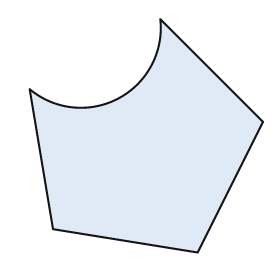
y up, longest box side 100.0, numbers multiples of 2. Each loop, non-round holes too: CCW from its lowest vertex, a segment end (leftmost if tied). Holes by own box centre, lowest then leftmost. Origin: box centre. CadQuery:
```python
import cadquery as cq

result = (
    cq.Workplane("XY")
    .moveTo(22.0, -50.0)
    .lineTo(50.0, 6.0)
    .lineTo(6.0, 50.0)
    .threePointArc((-12.0, 16.0), (-50.0, 20.0))
    .lineTo(-40.0, -40.0)
    .close()
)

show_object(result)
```